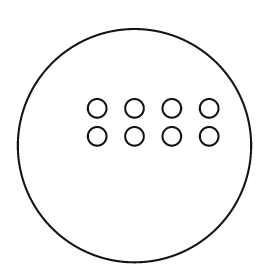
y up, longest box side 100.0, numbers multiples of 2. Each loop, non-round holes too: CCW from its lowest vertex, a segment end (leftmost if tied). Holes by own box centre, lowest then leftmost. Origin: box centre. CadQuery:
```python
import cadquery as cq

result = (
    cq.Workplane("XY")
    .moveTo(0.0, 0.0)
    .circle(50.0)
    .moveTo(-16.0, 4.0)
    .circle(4.0)
    .moveTo(0.0, 4.0)
    .circle(4.0)
    .moveTo(16.0, 4.0)
    .circle(4.0)
    .moveTo(32.0, 4.0)
    .circle(4.0)
    .moveTo(-16.0, 16.0)
    .circle(4.0)
    .moveTo(0.0, 16.0)
    .circle(4.0)
    .moveTo(16.0, 16.0)
    .circle(4.0)
    .moveTo(32.0, 16.0)
    .circle(4.0)
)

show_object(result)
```